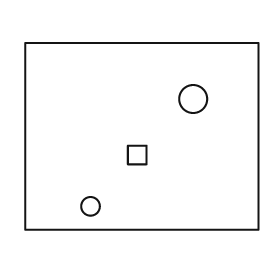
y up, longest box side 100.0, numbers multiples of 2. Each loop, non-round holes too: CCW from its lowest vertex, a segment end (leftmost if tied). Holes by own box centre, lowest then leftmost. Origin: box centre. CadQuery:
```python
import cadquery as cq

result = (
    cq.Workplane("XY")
    .moveTo(-50.0, -40.0)
    .lineTo(50.0, -40.0)
    .lineTo(50.0, 40.0)
    .lineTo(-50.0, 40.0)
    .close()
    .moveTo(-22.0, -30.0)
    .circle(4.0)
    .moveTo(-6.0, -12.0)
    .lineTo(2.0, -12.0)
    .lineTo(2.0, -4.0)
    .lineTo(-6.0, -4.0)
    .close()
    .moveTo(22.0, 16.0)
    .circle(6.0)
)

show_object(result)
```